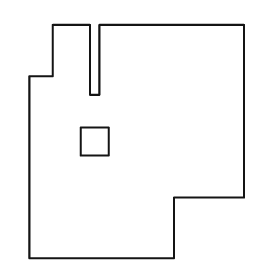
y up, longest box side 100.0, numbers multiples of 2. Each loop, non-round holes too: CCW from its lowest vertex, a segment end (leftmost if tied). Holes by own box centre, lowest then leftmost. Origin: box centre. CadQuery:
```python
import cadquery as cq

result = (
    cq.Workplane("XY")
    .moveTo(-46.0, -50.0)
    .lineTo(16.0, -50.0)
    .lineTo(16.0, -24.0)
    .lineTo(46.0, -24.0)
    .lineTo(46.0, 50.0)
    .lineTo(-16.0, 50.0)
    .lineTo(-16.0, 20.0)
    .lineTo(-20.0, 20.0)
    .lineTo(-20.0, 50.0)
    .lineTo(-36.0, 50.0)
    .lineTo(-36.0, 28.0)
    .lineTo(-46.0, 28.0)
    .close()
    .moveTo(-24.0, -6.0)
    .lineTo(-12.0, -6.0)
    .lineTo(-12.0, 6.0)
    .lineTo(-24.0, 6.0)
    .close()
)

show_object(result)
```